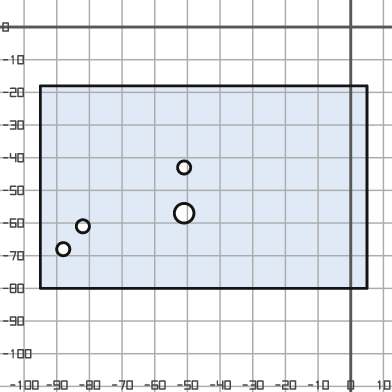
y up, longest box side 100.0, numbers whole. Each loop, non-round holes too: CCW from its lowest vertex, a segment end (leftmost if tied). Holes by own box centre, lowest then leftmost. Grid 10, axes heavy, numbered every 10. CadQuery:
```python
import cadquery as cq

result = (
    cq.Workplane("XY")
    .moveTo(-95.0, -80.0)
    .lineTo(5.0, -80.0)
    .lineTo(5.0, -18.0)
    .lineTo(-95.0, -18.0)
    .close()
    .moveTo(-88.0, -68.0)
    .circle(2.0)
    .moveTo(-82.0, -61.0)
    .circle(2.0)
    .moveTo(-51.0, -57.0)
    .circle(3.0)
    .moveTo(-51.0, -43.0)
    .circle(2.0)
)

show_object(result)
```